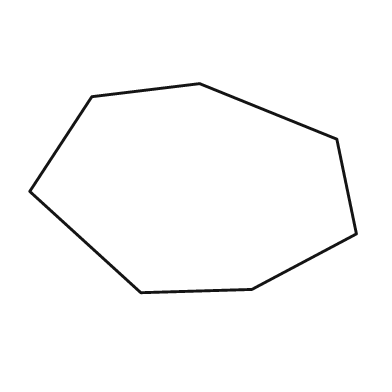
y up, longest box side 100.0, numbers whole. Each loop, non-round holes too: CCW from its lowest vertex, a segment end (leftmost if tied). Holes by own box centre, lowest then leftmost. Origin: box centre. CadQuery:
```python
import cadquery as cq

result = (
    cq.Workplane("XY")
    .moveTo(-16.0, -32.0)
    .lineTo(18.0, -31.0)
    .lineTo(50.0, -14.0)
    .lineTo(44.0, 15.0)
    .lineTo(2.0, 32.0)
    .lineTo(-31.0, 28.0)
    .lineTo(-50.0, -1.0)
    .close()
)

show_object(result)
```